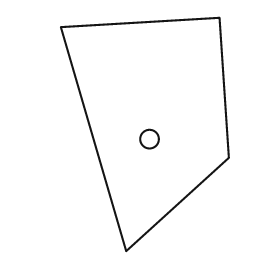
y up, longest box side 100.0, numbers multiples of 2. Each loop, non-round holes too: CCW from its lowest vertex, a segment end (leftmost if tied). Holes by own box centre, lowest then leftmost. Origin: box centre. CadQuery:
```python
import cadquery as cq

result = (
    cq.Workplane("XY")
    .moveTo(-8.0, -50.0)
    .lineTo(36.0, -10.0)
    .lineTo(32.0, 50.0)
    .lineTo(-36.0, 46.0)
    .close()
    .moveTo(2.0, -2.0)
    .circle(4.0)
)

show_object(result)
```